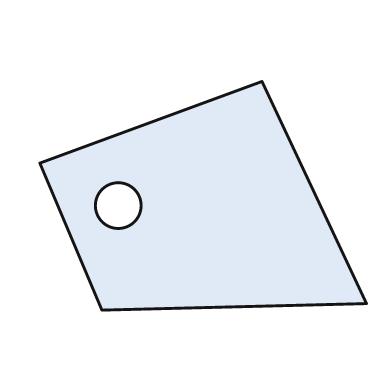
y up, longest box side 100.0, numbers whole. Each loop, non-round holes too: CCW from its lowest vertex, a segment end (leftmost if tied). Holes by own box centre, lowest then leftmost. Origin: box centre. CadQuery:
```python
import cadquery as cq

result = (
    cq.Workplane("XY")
    .moveTo(-31.0, -35.0)
    .lineTo(50.0, -33.0)
    .lineTo(18.0, 35.0)
    .lineTo(-50.0, 10.0)
    .close()
    .moveTo(-26.0, -3.0)
    .circle(7.0)
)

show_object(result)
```